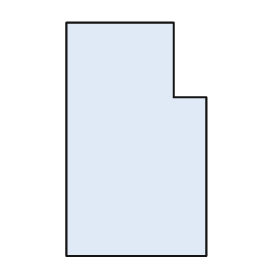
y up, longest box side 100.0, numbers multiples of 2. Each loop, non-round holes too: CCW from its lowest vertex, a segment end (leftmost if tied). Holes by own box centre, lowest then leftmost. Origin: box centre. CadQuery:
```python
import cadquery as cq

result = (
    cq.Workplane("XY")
    .moveTo(-30.0, -50.0)
    .lineTo(30.0, -50.0)
    .lineTo(30.0, 18.0)
    .lineTo(16.0, 18.0)
    .lineTo(16.0, 50.0)
    .lineTo(-30.0, 50.0)
    .close()
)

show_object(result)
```